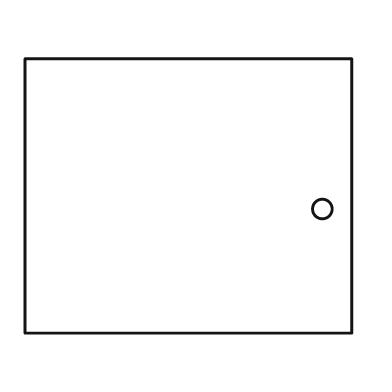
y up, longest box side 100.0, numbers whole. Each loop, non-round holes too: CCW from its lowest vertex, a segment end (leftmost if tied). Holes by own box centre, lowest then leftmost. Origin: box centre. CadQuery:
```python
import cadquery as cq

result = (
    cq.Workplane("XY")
    .moveTo(-50.0, -42.0)
    .lineTo(50.0, -42.0)
    .lineTo(50.0, 42.0)
    .lineTo(-50.0, 42.0)
    .close()
    .moveTo(41.0, -4.0)
    .circle(3.0)
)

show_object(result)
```